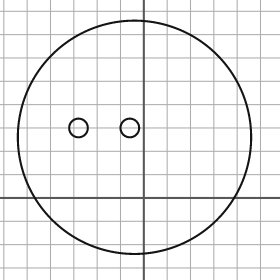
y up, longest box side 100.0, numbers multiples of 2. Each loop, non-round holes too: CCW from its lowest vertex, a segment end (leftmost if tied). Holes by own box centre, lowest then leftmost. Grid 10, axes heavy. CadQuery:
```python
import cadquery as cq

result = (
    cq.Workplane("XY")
    .moveTo(-4.0, 26.0)
    .circle(50.0)
    .moveTo(-28.0, 30.0)
    .circle(4.0)
    .moveTo(-6.0, 30.0)
    .circle(4.0)
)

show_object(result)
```